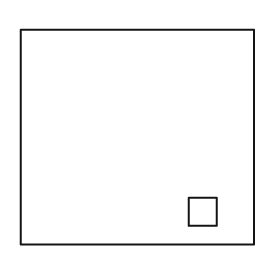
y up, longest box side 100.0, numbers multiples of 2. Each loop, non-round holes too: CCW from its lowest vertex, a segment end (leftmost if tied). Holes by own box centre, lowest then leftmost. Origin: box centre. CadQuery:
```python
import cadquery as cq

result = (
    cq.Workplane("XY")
    .moveTo(-50.0, -46.0)
    .lineTo(50.0, -46.0)
    .lineTo(50.0, 46.0)
    .lineTo(-50.0, 46.0)
    .close()
    .moveTo(22.0, -38.0)
    .lineTo(34.0, -38.0)
    .lineTo(34.0, -26.0)
    .lineTo(22.0, -26.0)
    .close()
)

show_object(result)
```